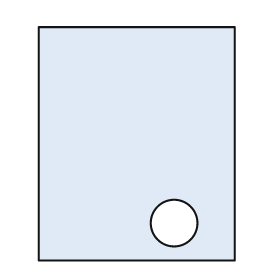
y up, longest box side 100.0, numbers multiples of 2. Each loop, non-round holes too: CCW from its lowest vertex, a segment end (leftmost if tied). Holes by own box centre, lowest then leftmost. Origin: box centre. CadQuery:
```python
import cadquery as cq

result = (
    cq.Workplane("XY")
    .moveTo(-42.0, -50.0)
    .lineTo(42.0, -50.0)
    .lineTo(42.0, 50.0)
    .lineTo(-42.0, 50.0)
    .close()
    .moveTo(16.0, -34.0)
    .circle(10.0)
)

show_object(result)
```